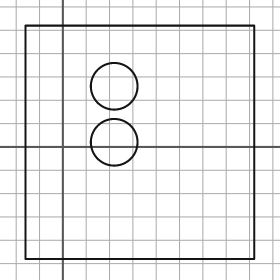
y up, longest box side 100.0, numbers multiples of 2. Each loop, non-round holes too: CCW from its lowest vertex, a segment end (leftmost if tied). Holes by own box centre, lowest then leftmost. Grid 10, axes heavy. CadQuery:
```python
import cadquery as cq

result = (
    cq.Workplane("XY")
    .moveTo(-16.0, -48.0)
    .lineTo(82.0, -48.0)
    .lineTo(82.0, 52.0)
    .lineTo(-16.0, 52.0)
    .close()
    .moveTo(22.0, 2.0)
    .circle(10.0)
    .moveTo(22.0, 26.0)
    .circle(10.0)
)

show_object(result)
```